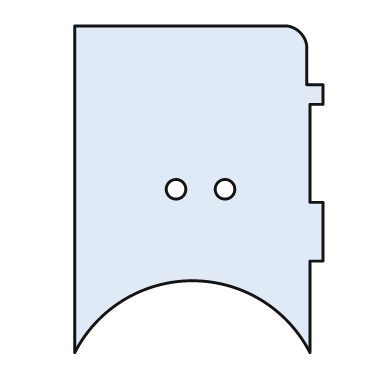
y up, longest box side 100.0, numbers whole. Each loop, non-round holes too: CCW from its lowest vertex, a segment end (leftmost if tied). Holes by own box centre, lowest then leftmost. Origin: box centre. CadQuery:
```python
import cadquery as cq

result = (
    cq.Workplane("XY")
    .moveTo(-38.0, -50.0)
    .threePointArc((-2.0, -28.0), (34.0, -50.0))
    .lineTo(34.0, -22.0)
    .lineTo(38.0, -22.0)
    .lineTo(38.0, -4.0)
    .lineTo(34.0, -4.0)
    .lineTo(34.0, 26.0)
    .lineTo(38.0, 26.0)
    .lineTo(38.0, 32.0)
    .lineTo(33.0, 32.0)
    .lineTo(33.0, 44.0)
    .threePointArc((31.0, 48.0), (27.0, 50.0))
    .lineTo(-38.0, 50.0)
    .close()
    .moveTo(-7.0, 0.0)
    .circle(3.0)
    .moveTo(8.0, 0.0)
    .circle(3.0)
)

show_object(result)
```